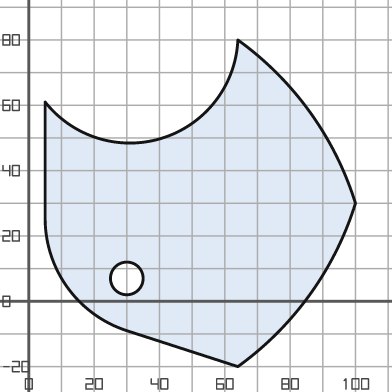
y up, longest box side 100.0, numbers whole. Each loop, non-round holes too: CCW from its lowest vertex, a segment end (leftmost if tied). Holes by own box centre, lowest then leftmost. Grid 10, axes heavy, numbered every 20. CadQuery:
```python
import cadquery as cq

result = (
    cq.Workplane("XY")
    .moveTo(64.0, -20.0)
    .threePointArc((86.0, 2.0), (100.0, 30.0))
    .threePointArc((86.0, 58.0), (64.0, 80.0))
    .threePointArc((41.0, 50.0), (5.0, 61.0))
    .lineTo(5.0, 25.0)
    .threePointArc((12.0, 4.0), (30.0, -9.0))
    .close()
    .moveTo(30.0, 7.0)
    .circle(5.0)
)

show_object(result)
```